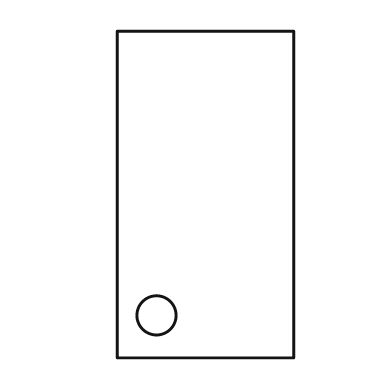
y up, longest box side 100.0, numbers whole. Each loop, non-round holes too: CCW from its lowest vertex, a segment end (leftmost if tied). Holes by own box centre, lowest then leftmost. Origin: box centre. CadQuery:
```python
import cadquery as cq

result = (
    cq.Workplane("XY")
    .moveTo(-27.0, -50.0)
    .lineTo(27.0, -50.0)
    .lineTo(27.0, 50.0)
    .lineTo(-27.0, 50.0)
    .close()
    .moveTo(-15.0, -37.0)
    .circle(6.0)
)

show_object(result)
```